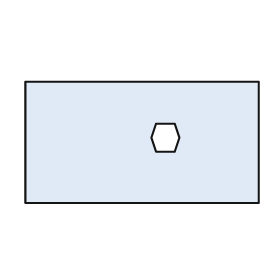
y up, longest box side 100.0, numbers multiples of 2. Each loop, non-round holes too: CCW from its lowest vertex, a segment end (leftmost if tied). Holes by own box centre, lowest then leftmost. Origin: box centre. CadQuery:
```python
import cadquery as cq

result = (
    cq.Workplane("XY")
    .moveTo(-50.0, -26.0)
    .lineTo(50.0, -26.0)
    .lineTo(50.0, 26.0)
    .lineTo(-50.0, 26.0)
    .close()
    .moveTo(6.0, -4.0)
    .lineTo(14.0, -4.0)
    .lineTo(16.0, 2.0)
    .lineTo(14.0, 8.0)
    .lineTo(6.0, 8.0)
    .lineTo(4.0, 2.0)
    .close()
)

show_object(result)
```